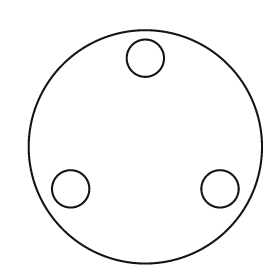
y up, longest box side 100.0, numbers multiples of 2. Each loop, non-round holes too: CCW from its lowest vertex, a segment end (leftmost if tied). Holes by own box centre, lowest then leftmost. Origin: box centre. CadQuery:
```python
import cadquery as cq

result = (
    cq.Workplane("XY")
    .moveTo(0.0, 0.0)
    .circle(50.0)
    .moveTo(-32.0, -18.0)
    .circle(8.0)
    .moveTo(32.0, -18.0)
    .circle(8.0)
    .moveTo(0.0, 38.0)
    .circle(8.0)
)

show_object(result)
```